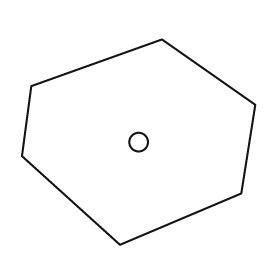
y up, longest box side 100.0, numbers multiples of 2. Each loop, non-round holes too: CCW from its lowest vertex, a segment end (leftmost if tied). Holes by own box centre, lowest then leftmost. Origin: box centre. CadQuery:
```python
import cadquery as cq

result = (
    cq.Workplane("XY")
    .moveTo(-8.0, -44.0)
    .lineTo(44.0, -22.0)
    .lineTo(50.0, 16.0)
    .lineTo(10.0, 44.0)
    .lineTo(-46.0, 24.0)
    .lineTo(-50.0, -6.0)
    .close()
    .moveTo(0.0, 0.0)
    .circle(4.0)
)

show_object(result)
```